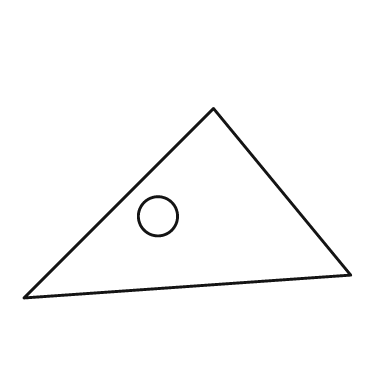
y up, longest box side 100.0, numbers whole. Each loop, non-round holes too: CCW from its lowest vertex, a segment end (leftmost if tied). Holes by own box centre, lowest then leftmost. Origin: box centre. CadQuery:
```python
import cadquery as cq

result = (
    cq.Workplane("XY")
    .moveTo(-50.0, -29.0)
    .lineTo(50.0, -22.0)
    .lineTo(8.0, 29.0)
    .close()
    .moveTo(-9.0, -4.0)
    .circle(6.0)
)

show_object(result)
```